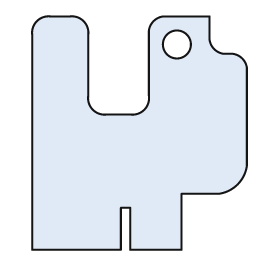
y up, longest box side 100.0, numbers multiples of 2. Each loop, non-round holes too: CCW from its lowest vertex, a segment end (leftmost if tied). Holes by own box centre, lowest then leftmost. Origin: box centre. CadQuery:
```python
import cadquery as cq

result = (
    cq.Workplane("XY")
    .moveTo(-46.0, -50.0)
    .lineTo(-8.0, -50.0)
    .lineTo(-8.0, -32.0)
    .lineTo(-4.0, -32.0)
    .lineTo(-4.0, -50.0)
    .lineTo(18.0, -50.0)
    .lineTo(18.0, -26.0)
    .lineTo(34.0, -26.0)
    .threePointArc((42.0, -22.0), (46.0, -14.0))
    .lineTo(46.0, 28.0)
    .threePointArc((44.0, 32.0), (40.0, 34.0))
    .lineTo(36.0, 34.0)
    .threePointArc((32.0, 36.0), (30.0, 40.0))
    .lineTo(30.0, 50.0)
    .lineTo(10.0, 50.0)
    .threePointArc((6.0, 48.0), (4.0, 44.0))
    .lineTo(4.0, 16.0)
    .threePointArc((2.0, 10.0), (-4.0, 8.0))
    .lineTo(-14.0, 8.0)
    .threePointArc((-20.0, 10.0), (-22.0, 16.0))
    .lineTo(-22.0, 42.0)
    .threePointArc((-24.0, 48.0), (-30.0, 50.0))
    .lineTo(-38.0, 50.0)
    .threePointArc((-44.0, 48.0), (-46.0, 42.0))
    .close()
    .moveTo(16.0, 38.0)
    .circle(6.0)
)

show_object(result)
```